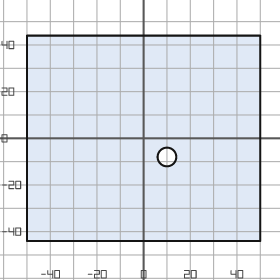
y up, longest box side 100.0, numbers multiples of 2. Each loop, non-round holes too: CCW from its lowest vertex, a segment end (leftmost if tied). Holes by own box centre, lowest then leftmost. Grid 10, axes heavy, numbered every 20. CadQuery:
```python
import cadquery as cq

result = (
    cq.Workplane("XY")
    .moveTo(-50.0, -44.0)
    .lineTo(50.0, -44.0)
    .lineTo(50.0, 44.0)
    .lineTo(-50.0, 44.0)
    .close()
    .moveTo(10.0, -8.0)
    .circle(4.0)
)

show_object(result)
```